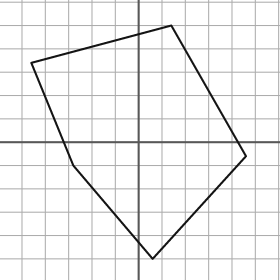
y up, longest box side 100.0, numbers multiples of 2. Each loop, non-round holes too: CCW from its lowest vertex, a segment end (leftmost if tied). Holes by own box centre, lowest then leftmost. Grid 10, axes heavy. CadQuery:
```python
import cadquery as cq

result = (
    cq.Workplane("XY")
    .moveTo(6.0, -50.0)
    .lineTo(46.0, -6.0)
    .lineTo(14.0, 50.0)
    .lineTo(-46.0, 34.0)
    .lineTo(-28.0, -10.0)
    .close()
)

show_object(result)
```